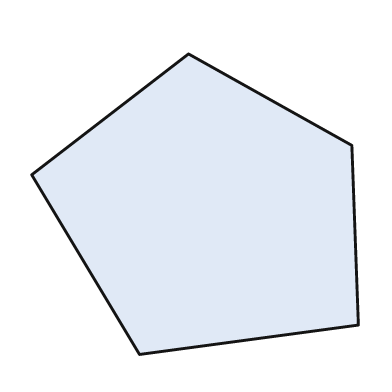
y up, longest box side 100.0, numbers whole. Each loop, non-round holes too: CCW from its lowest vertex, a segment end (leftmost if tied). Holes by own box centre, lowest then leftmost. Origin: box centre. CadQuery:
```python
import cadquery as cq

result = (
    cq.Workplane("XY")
    .moveTo(-17.0, -46.0)
    .lineTo(50.0, -37.0)
    .lineTo(48.0, 18.0)
    .lineTo(-2.0, 46.0)
    .lineTo(-50.0, 9.0)
    .close()
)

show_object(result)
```